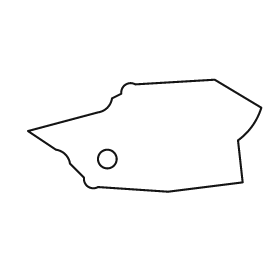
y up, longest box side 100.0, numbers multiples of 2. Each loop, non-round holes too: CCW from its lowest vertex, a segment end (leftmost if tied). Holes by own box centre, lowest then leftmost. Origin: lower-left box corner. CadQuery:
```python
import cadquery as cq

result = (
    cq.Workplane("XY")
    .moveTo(60.0, 0.0)
    .lineTo(92.0, 4.0)
    .lineTo(90.0, 22.0)
    .threePointArc((96.0, 28.0), (100.0, 36.0))
    .lineTo(80.0, 48.0)
    .lineTo(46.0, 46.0)
    .threePointArc((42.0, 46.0), (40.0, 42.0))
    .lineTo(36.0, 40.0)
    .threePointArc((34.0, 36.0), (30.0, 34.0))
    .lineTo(0.0, 26.0)
    .lineTo(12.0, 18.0)
    .threePointArc((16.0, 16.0), (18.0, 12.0))
    .lineTo(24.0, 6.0)
    .threePointArc((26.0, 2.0), (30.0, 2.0))
    .close()
    .moveTo(34.0, 14.0)
    .circle(4.0)
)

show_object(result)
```